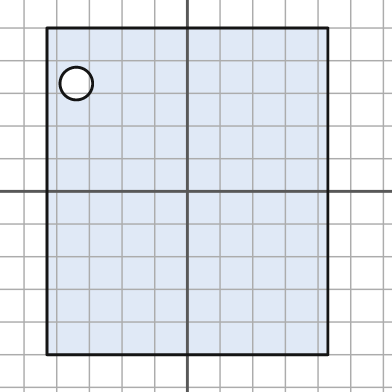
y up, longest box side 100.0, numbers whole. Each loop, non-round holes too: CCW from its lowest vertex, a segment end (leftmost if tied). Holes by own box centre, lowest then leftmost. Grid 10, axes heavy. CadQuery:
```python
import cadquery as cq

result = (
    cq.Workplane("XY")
    .moveTo(-43.0, -50.0)
    .lineTo(43.0, -50.0)
    .lineTo(43.0, 50.0)
    .lineTo(-43.0, 50.0)
    .close()
    .moveTo(-34.0, 33.0)
    .circle(5.0)
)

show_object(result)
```